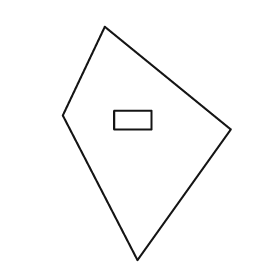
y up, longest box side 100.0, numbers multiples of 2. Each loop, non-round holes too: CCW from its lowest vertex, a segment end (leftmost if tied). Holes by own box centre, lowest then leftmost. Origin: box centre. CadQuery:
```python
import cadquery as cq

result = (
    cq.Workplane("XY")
    .moveTo(-4.0, -50.0)
    .lineTo(36.0, 6.0)
    .lineTo(-18.0, 50.0)
    .lineTo(-36.0, 12.0)
    .close()
    .moveTo(-14.0, 6.0)
    .lineTo(2.0, 6.0)
    .lineTo(2.0, 14.0)
    .lineTo(-14.0, 14.0)
    .close()
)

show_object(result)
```